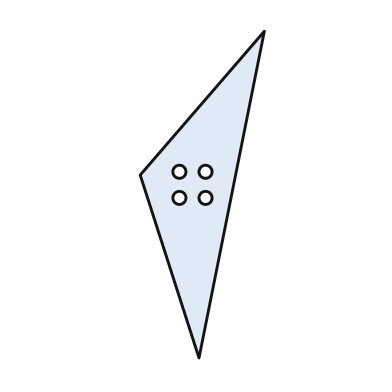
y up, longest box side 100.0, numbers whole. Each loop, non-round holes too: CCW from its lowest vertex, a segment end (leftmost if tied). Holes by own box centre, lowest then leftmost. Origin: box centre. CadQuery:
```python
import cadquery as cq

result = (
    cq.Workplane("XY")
    .moveTo(-1.0, -50.0)
    .lineTo(19.0, 50.0)
    .lineTo(-19.0, 6.0)
    .close()
    .moveTo(-7.0, -1.0)
    .circle(2.0)
    .moveTo(1.0, -1.0)
    .circle(2.0)
    .moveTo(-7.0, 7.0)
    .circle(2.0)
    .moveTo(1.0, 7.0)
    .circle(2.0)
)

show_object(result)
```